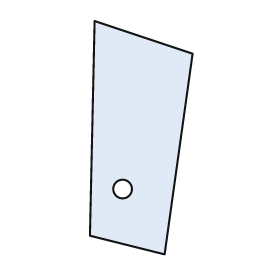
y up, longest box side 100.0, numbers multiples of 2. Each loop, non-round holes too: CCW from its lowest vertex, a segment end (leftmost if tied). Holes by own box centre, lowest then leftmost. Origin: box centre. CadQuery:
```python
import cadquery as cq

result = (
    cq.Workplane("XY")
    .moveTo(10.0, -50.0)
    .lineTo(22.0, 36.0)
    .lineTo(-20.0, 50.0)
    .lineTo(-22.0, -42.0)
    .close()
    .moveTo(-8.0, -22.0)
    .circle(4.0)
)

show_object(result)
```